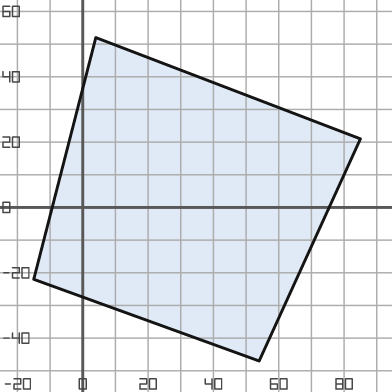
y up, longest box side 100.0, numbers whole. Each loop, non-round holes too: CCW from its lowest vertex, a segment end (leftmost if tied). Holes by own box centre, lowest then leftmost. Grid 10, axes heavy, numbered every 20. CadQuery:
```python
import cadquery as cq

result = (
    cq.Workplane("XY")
    .moveTo(54.0, -47.0)
    .lineTo(85.0, 21.0)
    .lineTo(4.0, 52.0)
    .lineTo(-15.0, -22.0)
    .close()
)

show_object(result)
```